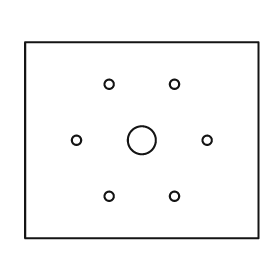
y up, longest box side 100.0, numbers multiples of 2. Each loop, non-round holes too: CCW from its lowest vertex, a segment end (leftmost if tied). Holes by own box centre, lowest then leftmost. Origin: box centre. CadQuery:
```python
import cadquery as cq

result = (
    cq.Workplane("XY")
    .moveTo(-50.0, -42.0)
    .lineTo(50.0, -42.0)
    .lineTo(50.0, 42.0)
    .lineTo(-50.0, 42.0)
    .close()
    .moveTo(-14.0, -24.0)
    .circle(2.0)
    .moveTo(14.0, -24.0)
    .circle(2.0)
    .moveTo(-28.0, 0.0)
    .circle(2.0)
    .moveTo(0.0, 0.0)
    .circle(6.0)
    .moveTo(28.0, 0.0)
    .circle(2.0)
    .moveTo(-14.0, 24.0)
    .circle(2.0)
    .moveTo(14.0, 24.0)
    .circle(2.0)
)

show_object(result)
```